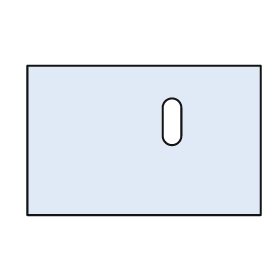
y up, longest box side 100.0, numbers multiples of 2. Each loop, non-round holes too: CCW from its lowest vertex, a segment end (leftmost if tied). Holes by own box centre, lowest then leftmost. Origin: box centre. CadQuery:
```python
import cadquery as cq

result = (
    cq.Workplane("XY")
    .moveTo(-50.0, -32.0)
    .lineTo(50.0, -32.0)
    .lineTo(50.0, 32.0)
    .lineTo(-50.0, 32.0)
    .close()
    .moveTo(8.0, 2.0)
    .threePointArc((12.0, -2.0), (16.0, 2.0))
    .lineTo(16.0, 14.0)
    .threePointArc((12.0, 18.0), (8.0, 14.0))
    .close()
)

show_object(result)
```